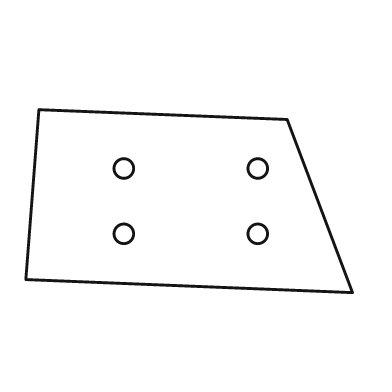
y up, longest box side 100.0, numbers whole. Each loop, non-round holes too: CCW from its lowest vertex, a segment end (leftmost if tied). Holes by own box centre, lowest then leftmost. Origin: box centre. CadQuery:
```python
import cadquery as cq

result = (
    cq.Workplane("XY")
    .moveTo(50.0, -28.0)
    .lineTo(30.0, 25.0)
    .lineTo(-46.0, 28.0)
    .lineTo(-50.0, -24.0)
    .close()
    .moveTo(-20.0, -10.0)
    .circle(3.0)
    .moveTo(21.0, -10.0)
    .circle(3.0)
    .moveTo(-20.0, 10.0)
    .circle(3.0)
    .moveTo(21.0, 10.0)
    .circle(3.0)
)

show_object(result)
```